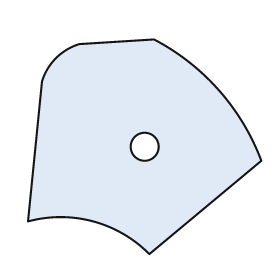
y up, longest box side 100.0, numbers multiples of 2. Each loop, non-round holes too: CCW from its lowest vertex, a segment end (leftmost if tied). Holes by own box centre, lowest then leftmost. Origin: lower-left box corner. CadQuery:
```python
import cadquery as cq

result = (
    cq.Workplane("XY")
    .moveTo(52.0, 0.0)
    .lineTo(100.0, 40.0)
    .threePointArc((82.0, 70.0), (54.0, 92.0))
    .lineTo(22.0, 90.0)
    .threePointArc((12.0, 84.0), (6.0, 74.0))
    .lineTo(0.0, 14.0)
    .threePointArc((28.0, 14.0), (52.0, 0.0))
    .close()
    .moveTo(50.0, 46.0)
    .circle(6.0)
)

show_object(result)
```